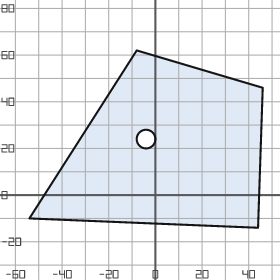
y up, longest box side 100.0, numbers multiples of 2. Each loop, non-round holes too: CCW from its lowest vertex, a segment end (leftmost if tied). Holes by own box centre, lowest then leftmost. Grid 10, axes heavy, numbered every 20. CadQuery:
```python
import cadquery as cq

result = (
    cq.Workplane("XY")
    .moveTo(44.0, -14.0)
    .lineTo(46.0, 46.0)
    .lineTo(-8.0, 62.0)
    .lineTo(-54.0, -10.0)
    .close()
    .moveTo(-4.0, 24.0)
    .circle(4.0)
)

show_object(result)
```